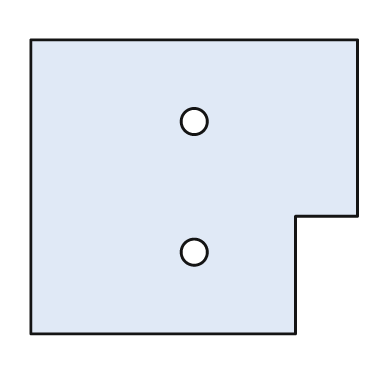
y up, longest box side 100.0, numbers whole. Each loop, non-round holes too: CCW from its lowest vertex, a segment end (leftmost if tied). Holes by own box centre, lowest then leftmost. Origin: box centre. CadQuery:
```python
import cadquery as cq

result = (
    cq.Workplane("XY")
    .moveTo(-50.0, -45.0)
    .lineTo(31.0, -45.0)
    .lineTo(31.0, -9.0)
    .lineTo(50.0, -9.0)
    .lineTo(50.0, 45.0)
    .lineTo(-50.0, 45.0)
    .close()
    .moveTo(0.0, -20.0)
    .circle(4.0)
    .moveTo(0.0, 20.0)
    .circle(4.0)
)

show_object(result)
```